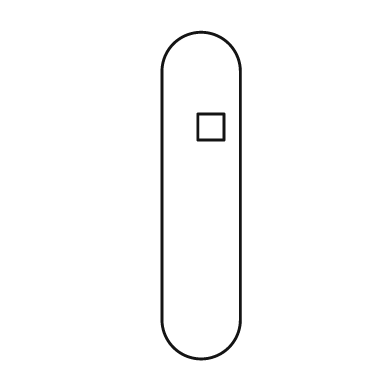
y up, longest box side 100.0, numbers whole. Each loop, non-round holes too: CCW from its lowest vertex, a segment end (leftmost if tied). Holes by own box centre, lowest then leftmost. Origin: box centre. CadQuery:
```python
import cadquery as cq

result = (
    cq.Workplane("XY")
    .moveTo(-12.0, -38.0)
    .threePointArc((0.0, -50.0), (12.0, -38.0))
    .lineTo(12.0, 38.0)
    .threePointArc((0.0, 50.0), (-12.0, 38.0))
    .close()
    .moveTo(-1.0, 17.0)
    .lineTo(7.0, 17.0)
    .lineTo(7.0, 25.0)
    .lineTo(-1.0, 25.0)
    .close()
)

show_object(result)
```